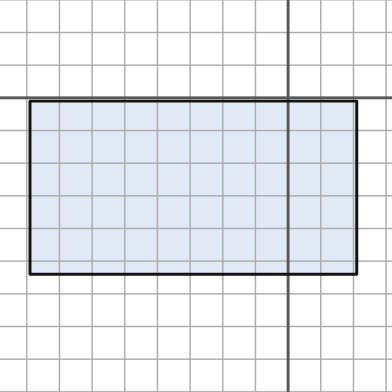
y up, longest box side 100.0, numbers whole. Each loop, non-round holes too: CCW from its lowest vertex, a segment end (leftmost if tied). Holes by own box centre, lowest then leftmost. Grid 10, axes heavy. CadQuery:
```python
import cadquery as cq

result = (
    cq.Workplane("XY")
    .moveTo(-79.0, -54.0)
    .lineTo(21.0, -54.0)
    .lineTo(21.0, -1.0)
    .lineTo(-79.0, -1.0)
    .close()
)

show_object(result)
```